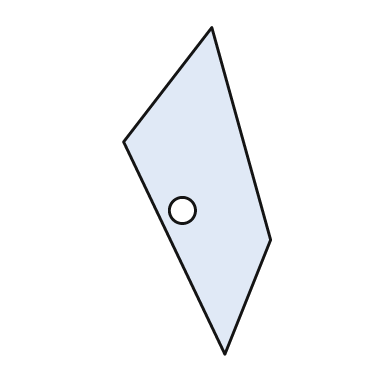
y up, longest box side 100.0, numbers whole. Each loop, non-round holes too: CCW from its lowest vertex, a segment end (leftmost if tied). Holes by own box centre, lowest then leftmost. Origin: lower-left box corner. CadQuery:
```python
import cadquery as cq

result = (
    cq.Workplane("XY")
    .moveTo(31.0, 0.0)
    .lineTo(45.0, 35.0)
    .lineTo(27.0, 100.0)
    .lineTo(0.0, 65.0)
    .close()
    .moveTo(18.0, 44.0)
    .circle(4.0)
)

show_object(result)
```